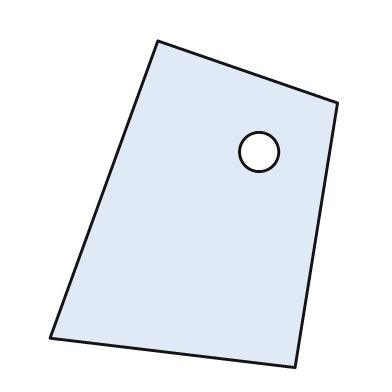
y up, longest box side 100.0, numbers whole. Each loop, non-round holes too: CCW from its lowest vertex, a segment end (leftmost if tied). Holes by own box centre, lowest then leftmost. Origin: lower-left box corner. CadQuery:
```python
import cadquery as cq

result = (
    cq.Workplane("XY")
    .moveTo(75.0, 0.0)
    .lineTo(88.0, 81.0)
    .lineTo(33.0, 100.0)
    .lineTo(0.0, 9.0)
    .close()
    .moveTo(64.0, 66.0)
    .circle(6.0)
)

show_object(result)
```